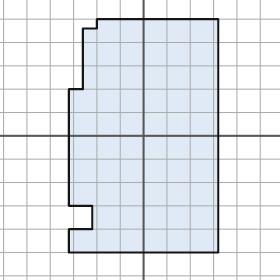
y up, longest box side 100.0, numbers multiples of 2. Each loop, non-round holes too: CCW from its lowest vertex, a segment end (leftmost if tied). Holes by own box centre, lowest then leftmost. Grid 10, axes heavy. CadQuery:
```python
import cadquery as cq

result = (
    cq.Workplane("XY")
    .moveTo(-32.0, -50.0)
    .lineTo(32.0, -50.0)
    .lineTo(32.0, 50.0)
    .lineTo(-20.0, 50.0)
    .lineTo(-20.0, 46.0)
    .lineTo(-26.0, 46.0)
    .lineTo(-26.0, 20.0)
    .lineTo(-32.0, 20.0)
    .lineTo(-32.0, -30.0)
    .lineTo(-22.0, -30.0)
    .lineTo(-22.0, -40.0)
    .lineTo(-32.0, -40.0)
    .close()
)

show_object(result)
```